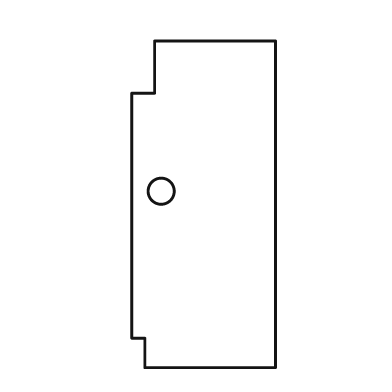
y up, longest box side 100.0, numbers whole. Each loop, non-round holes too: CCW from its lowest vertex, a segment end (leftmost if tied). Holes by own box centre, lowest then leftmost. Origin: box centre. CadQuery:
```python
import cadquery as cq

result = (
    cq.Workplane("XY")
    .moveTo(-18.0, -50.0)
    .lineTo(22.0, -50.0)
    .lineTo(22.0, 50.0)
    .lineTo(-15.0, 50.0)
    .lineTo(-15.0, 34.0)
    .lineTo(-22.0, 34.0)
    .lineTo(-22.0, -41.0)
    .lineTo(-18.0, -41.0)
    .close()
    .moveTo(-13.0, 4.0)
    .circle(4.0)
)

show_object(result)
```